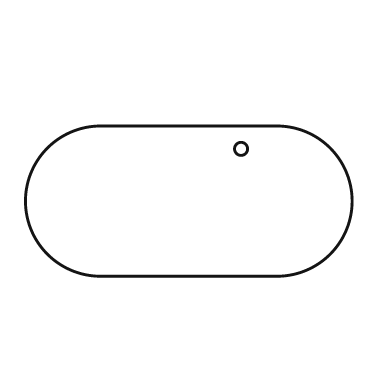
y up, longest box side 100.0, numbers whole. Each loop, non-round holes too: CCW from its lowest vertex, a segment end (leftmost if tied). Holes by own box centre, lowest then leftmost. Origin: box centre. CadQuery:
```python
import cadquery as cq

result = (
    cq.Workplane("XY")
    .moveTo(-27.0, -23.0)
    .lineTo(27.0, -23.0)
    .threePointArc((50.0, 0.0), (27.0, 23.0))
    .lineTo(-27.0, 23.0)
    .threePointArc((-50.0, 0.0), (-27.0, -23.0))
    .close()
    .moveTo(16.0, 16.0)
    .circle(2.0)
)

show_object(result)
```